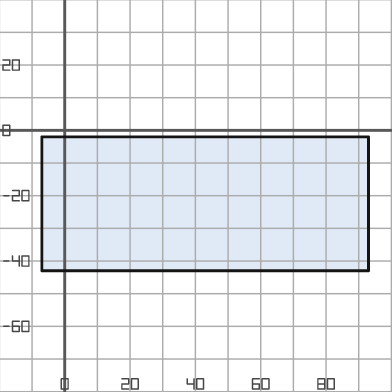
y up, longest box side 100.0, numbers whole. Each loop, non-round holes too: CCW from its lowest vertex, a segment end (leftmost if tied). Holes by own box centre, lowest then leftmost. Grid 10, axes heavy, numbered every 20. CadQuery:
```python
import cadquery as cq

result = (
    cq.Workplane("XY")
    .moveTo(-7.0, -43.0)
    .lineTo(93.0, -43.0)
    .lineTo(93.0, -2.0)
    .lineTo(-7.0, -2.0)
    .close()
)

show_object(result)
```